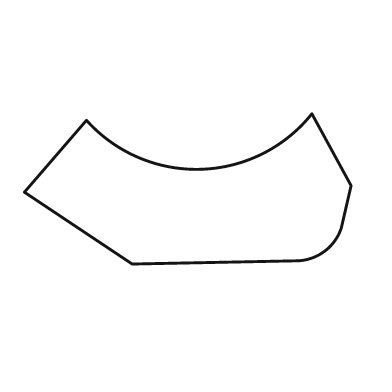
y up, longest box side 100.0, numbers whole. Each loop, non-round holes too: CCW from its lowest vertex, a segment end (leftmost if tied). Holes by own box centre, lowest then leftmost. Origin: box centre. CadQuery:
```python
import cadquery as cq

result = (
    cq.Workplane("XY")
    .moveTo(-17.0, -23.0)
    .lineTo(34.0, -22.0)
    .threePointArc((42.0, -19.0), (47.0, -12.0))
    .lineTo(50.0, 1.0)
    .lineTo(38.0, 23.0)
    .threePointArc((4.0, 6.0), (-31.0, 21.0))
    .lineTo(-50.0, -1.0)
    .close()
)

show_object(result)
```